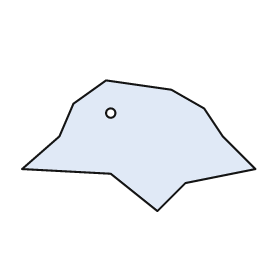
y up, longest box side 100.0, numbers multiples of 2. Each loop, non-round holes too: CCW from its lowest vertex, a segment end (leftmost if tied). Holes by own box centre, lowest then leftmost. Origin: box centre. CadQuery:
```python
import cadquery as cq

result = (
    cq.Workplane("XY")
    .moveTo(8.0, -28.0)
    .lineTo(20.0, -16.0)
    .lineTo(50.0, -10.0)
    .lineTo(36.0, 4.0)
    .lineTo(28.0, 16.0)
    .lineTo(14.0, 24.0)
    .lineTo(-14.0, 28.0)
    .lineTo(-28.0, 18.0)
    .lineTo(-34.0, 4.0)
    .lineTo(-50.0, -10.0)
    .lineTo(-12.0, -12.0)
    .close()
    .moveTo(-12.0, 14.0)
    .circle(2.0)
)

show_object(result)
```